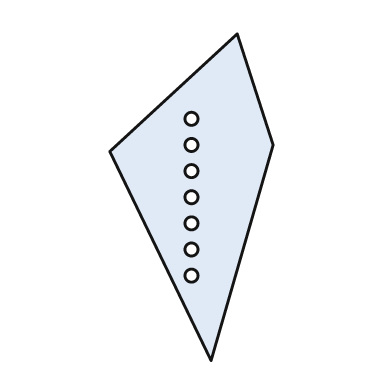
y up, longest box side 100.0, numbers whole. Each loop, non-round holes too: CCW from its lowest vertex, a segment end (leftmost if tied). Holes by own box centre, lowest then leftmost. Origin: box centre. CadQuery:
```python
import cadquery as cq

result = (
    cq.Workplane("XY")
    .moveTo(6.0, -50.0)
    .lineTo(25.0, 16.0)
    .lineTo(14.0, 50.0)
    .lineTo(-25.0, 14.0)
    .close()
    .moveTo(0.0, -24.0)
    .circle(2.0)
    .moveTo(0.0, -16.0)
    .circle(2.0)
    .moveTo(0.0, -8.0)
    .circle(2.0)
    .moveTo(0.0, 0.0)
    .circle(2.0)
    .moveTo(0.0, 8.0)
    .circle(2.0)
    .moveTo(0.0, 16.0)
    .circle(2.0)
    .moveTo(0.0, 24.0)
    .circle(2.0)
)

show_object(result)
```